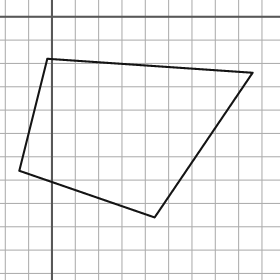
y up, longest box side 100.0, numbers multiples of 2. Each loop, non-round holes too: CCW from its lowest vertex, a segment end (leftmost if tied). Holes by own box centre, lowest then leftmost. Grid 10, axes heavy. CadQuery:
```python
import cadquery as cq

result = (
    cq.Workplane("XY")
    .moveTo(44.0, -86.0)
    .lineTo(86.0, -24.0)
    .lineTo(-2.0, -18.0)
    .lineTo(-14.0, -66.0)
    .close()
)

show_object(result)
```